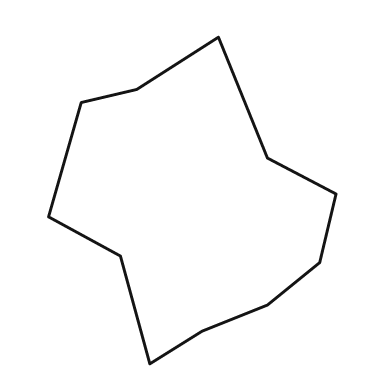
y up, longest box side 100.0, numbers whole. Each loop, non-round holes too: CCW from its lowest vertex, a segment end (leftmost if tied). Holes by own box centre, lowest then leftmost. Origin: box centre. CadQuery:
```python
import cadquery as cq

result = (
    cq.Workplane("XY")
    .moveTo(-13.0, -50.0)
    .lineTo(3.0, -40.0)
    .lineTo(23.0, -32.0)
    .lineTo(39.0, -19.0)
    .lineTo(44.0, 2.0)
    .lineTo(23.0, 13.0)
    .lineTo(8.0, 50.0)
    .lineTo(-17.0, 34.0)
    .lineTo(-34.0, 30.0)
    .lineTo(-44.0, -5.0)
    .lineTo(-22.0, -17.0)
    .close()
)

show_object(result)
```